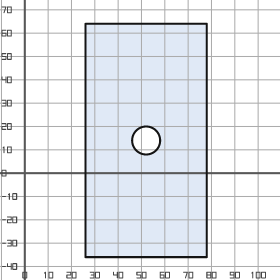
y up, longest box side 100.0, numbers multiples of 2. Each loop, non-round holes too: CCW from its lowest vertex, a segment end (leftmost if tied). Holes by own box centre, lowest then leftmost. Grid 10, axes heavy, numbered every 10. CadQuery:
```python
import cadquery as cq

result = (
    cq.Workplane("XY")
    .moveTo(26.0, -36.0)
    .lineTo(78.0, -36.0)
    .lineTo(78.0, 64.0)
    .lineTo(26.0, 64.0)
    .close()
    .moveTo(52.0, 14.0)
    .circle(6.0)
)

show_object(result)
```